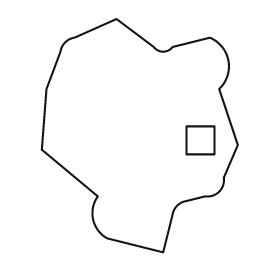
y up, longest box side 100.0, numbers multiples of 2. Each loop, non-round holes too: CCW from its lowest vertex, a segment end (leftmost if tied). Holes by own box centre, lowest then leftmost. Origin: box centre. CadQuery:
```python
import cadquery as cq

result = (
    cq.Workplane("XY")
    .moveTo(10.0, -50.0)
    .lineTo(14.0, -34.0)
    .threePointArc((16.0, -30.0), (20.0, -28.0))
    .lineTo(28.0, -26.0)
    .threePointArc((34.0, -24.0), (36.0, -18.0))
    .lineTo(42.0, -4.0)
    .lineTo(34.0, 20.0)
    .threePointArc((38.0, 32.0), (30.0, 42.0))
    .lineTo(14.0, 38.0)
    .threePointArc((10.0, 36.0), (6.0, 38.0))
    .lineTo(-10.0, 50.0)
    .lineTo(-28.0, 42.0)
    .threePointArc((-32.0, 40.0), (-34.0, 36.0))
    .lineTo(-40.0, 20.0)
    .lineTo(-42.0, -6.0)
    .lineTo(-18.0, -26.0)
    .threePointArc((-20.0, -36.0), (-14.0, -44.0))
    .close()
    .moveTo(20.0, -8.0)
    .lineTo(32.0, -8.0)
    .lineTo(32.0, 4.0)
    .lineTo(20.0, 4.0)
    .close()
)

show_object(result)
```